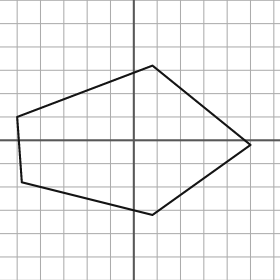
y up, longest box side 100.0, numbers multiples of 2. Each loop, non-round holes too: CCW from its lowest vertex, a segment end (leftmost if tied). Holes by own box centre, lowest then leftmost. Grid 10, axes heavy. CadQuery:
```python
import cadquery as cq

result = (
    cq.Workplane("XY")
    .moveTo(8.0, -32.0)
    .lineTo(50.0, -2.0)
    .lineTo(8.0, 32.0)
    .lineTo(-50.0, 10.0)
    .lineTo(-48.0, -18.0)
    .close()
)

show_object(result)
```